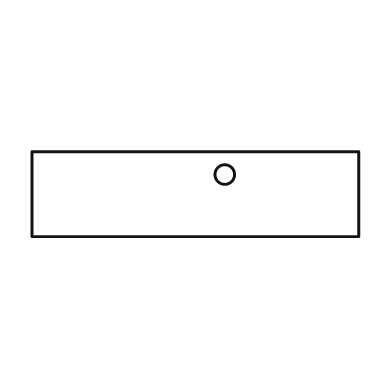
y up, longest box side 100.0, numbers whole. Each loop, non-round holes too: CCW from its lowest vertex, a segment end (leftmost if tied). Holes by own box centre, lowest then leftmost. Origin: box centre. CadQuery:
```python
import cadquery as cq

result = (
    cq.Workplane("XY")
    .moveTo(-50.0, -13.0)
    .lineTo(50.0, -13.0)
    .lineTo(50.0, 13.0)
    .lineTo(-50.0, 13.0)
    .close()
    .moveTo(9.0, 6.0)
    .circle(3.0)
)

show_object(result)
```